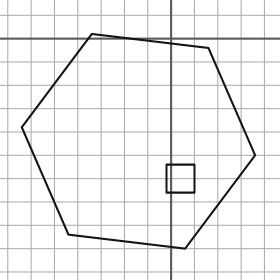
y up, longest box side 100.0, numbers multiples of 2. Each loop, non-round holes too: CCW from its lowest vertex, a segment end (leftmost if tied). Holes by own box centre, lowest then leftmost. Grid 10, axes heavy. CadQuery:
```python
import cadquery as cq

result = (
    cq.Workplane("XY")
    .moveTo(6.0, -90.0)
    .lineTo(36.0, -50.0)
    .lineTo(16.0, -4.0)
    .lineTo(-34.0, 2.0)
    .lineTo(-64.0, -38.0)
    .lineTo(-44.0, -84.0)
    .close()
    .moveTo(-2.0, -66.0)
    .lineTo(10.0, -66.0)
    .lineTo(10.0, -54.0)
    .lineTo(-2.0, -54.0)
    .close()
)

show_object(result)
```